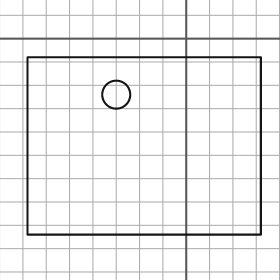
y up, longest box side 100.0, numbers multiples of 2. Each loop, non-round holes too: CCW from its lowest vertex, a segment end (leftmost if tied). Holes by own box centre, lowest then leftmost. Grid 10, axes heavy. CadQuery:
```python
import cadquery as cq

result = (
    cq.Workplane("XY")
    .moveTo(-68.0, -84.0)
    .lineTo(32.0, -84.0)
    .lineTo(32.0, -8.0)
    .lineTo(-68.0, -8.0)
    .close()
    .moveTo(-30.0, -24.0)
    .circle(6.0)
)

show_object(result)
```